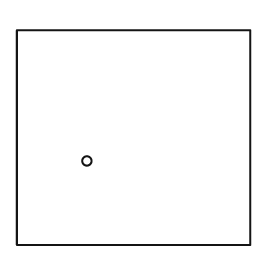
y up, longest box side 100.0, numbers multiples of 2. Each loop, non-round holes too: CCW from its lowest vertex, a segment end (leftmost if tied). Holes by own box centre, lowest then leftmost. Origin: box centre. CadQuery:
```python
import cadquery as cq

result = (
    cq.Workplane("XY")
    .moveTo(-50.0, -46.0)
    .lineTo(50.0, -46.0)
    .lineTo(50.0, 46.0)
    .lineTo(-50.0, 46.0)
    .close()
    .moveTo(-20.0, -10.0)
    .circle(2.0)
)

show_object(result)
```